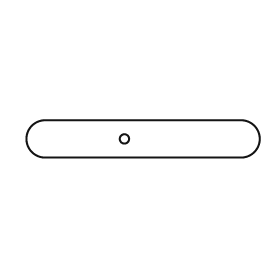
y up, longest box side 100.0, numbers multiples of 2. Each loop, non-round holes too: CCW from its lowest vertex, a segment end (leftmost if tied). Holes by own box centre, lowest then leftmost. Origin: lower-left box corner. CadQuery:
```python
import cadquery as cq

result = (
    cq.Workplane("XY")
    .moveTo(8.0, 0.0)
    .lineTo(92.0, 0.0)
    .threePointArc((100.0, 8.0), (92.0, 16.0))
    .lineTo(8.0, 16.0)
    .threePointArc((0.0, 8.0), (8.0, 0.0))
    .close()
    .moveTo(42.0, 8.0)
    .circle(2.0)
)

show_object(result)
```